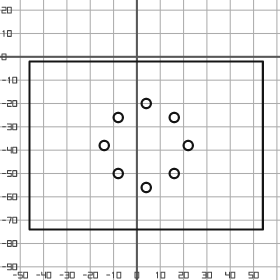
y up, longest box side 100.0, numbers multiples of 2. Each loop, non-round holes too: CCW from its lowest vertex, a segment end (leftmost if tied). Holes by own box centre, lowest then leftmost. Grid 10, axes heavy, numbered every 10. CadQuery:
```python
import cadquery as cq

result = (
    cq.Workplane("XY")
    .moveTo(-46.0, -74.0)
    .lineTo(54.0, -74.0)
    .lineTo(54.0, -2.0)
    .lineTo(-46.0, -2.0)
    .close()
    .moveTo(4.0, -56.0)
    .circle(2.0)
    .moveTo(-8.0, -50.0)
    .circle(2.0)
    .moveTo(16.0, -50.0)
    .circle(2.0)
    .moveTo(-14.0, -38.0)
    .circle(2.0)
    .moveTo(22.0, -38.0)
    .circle(2.0)
    .moveTo(-8.0, -26.0)
    .circle(2.0)
    .moveTo(16.0, -26.0)
    .circle(2.0)
    .moveTo(4.0, -20.0)
    .circle(2.0)
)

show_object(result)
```